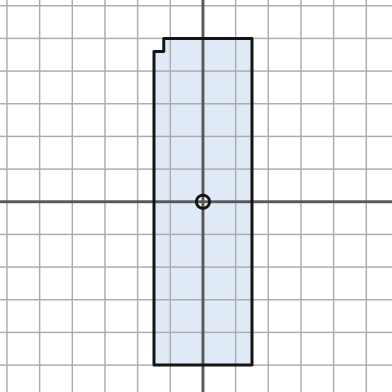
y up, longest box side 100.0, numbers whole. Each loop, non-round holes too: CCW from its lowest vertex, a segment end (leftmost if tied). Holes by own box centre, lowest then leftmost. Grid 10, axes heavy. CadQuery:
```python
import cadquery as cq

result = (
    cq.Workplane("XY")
    .moveTo(-15.0, -50.0)
    .lineTo(15.0, -50.0)
    .lineTo(15.0, 50.0)
    .lineTo(-12.0, 50.0)
    .lineTo(-12.0, 46.0)
    .lineTo(-15.0, 46.0)
    .close()
    .moveTo(0.0, 0.0)
    .circle(2.0)
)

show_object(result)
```